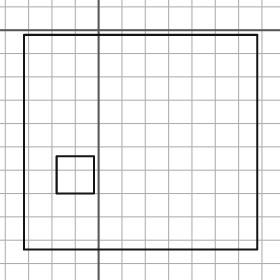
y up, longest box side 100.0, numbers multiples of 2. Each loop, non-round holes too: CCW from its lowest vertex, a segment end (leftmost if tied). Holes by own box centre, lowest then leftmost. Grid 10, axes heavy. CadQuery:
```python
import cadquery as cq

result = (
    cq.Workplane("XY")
    .moveTo(-32.0, -94.0)
    .lineTo(68.0, -94.0)
    .lineTo(68.0, -2.0)
    .lineTo(-32.0, -2.0)
    .close()
    .moveTo(-18.0, -70.0)
    .lineTo(-2.0, -70.0)
    .lineTo(-2.0, -54.0)
    .lineTo(-18.0, -54.0)
    .close()
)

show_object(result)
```